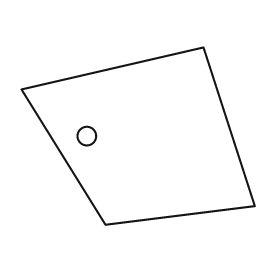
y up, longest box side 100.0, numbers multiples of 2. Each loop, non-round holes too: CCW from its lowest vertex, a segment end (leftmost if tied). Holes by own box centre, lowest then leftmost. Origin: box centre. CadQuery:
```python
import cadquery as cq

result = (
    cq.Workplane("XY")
    .moveTo(-14.0, -38.0)
    .lineTo(50.0, -30.0)
    .lineTo(28.0, 38.0)
    .lineTo(-50.0, 20.0)
    .close()
    .moveTo(-22.0, 0.0)
    .circle(4.0)
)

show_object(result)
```